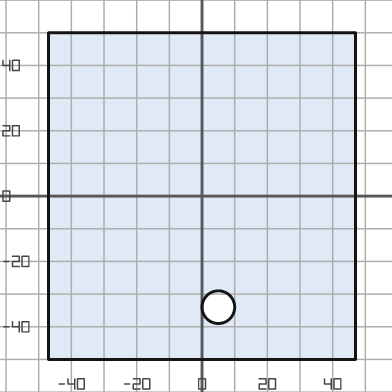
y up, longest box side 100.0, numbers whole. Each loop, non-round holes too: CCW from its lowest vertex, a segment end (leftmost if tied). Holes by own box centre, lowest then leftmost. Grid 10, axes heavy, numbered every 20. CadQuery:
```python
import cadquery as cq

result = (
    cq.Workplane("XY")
    .moveTo(-47.0, -50.0)
    .lineTo(47.0, -50.0)
    .lineTo(47.0, 50.0)
    .lineTo(-47.0, 50.0)
    .close()
    .moveTo(5.0, -34.0)
    .circle(5.0)
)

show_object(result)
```